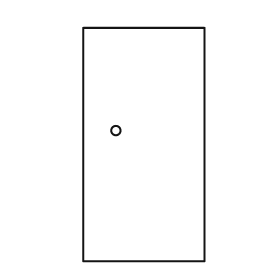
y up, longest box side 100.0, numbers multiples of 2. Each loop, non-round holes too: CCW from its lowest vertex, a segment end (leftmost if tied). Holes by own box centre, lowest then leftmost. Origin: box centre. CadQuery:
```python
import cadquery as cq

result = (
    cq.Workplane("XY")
    .moveTo(-26.0, -50.0)
    .lineTo(26.0, -50.0)
    .lineTo(26.0, 50.0)
    .lineTo(-26.0, 50.0)
    .close()
    .moveTo(-12.0, 6.0)
    .circle(2.0)
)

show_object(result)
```